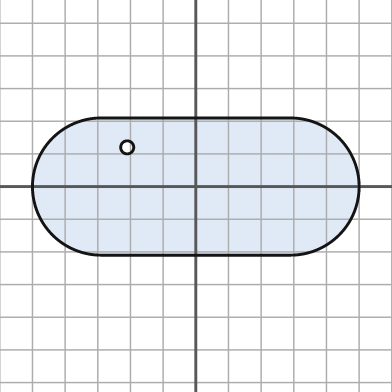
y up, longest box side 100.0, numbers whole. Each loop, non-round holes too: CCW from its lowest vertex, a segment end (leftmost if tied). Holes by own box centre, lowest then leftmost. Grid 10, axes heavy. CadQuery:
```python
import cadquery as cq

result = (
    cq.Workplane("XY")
    .moveTo(-29.0, -21.0)
    .lineTo(29.0, -21.0)
    .threePointArc((50.0, 0.0), (29.0, 21.0))
    .lineTo(-29.0, 21.0)
    .threePointArc((-50.0, 0.0), (-29.0, -21.0))
    .close()
    .moveTo(-21.0, 12.0)
    .circle(2.0)
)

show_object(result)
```